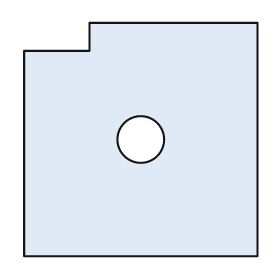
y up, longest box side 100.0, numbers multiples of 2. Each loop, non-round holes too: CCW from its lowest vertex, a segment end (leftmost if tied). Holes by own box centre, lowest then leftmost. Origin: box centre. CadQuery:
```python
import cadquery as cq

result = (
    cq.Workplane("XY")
    .moveTo(-50.0, -50.0)
    .lineTo(50.0, -50.0)
    .lineTo(50.0, 50.0)
    .lineTo(-22.0, 50.0)
    .lineTo(-22.0, 38.0)
    .lineTo(-50.0, 38.0)
    .close()
    .moveTo(0.0, 0.0)
    .circle(10.0)
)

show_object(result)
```